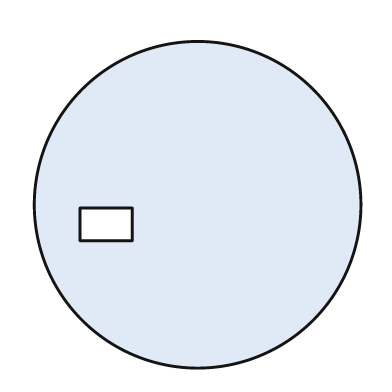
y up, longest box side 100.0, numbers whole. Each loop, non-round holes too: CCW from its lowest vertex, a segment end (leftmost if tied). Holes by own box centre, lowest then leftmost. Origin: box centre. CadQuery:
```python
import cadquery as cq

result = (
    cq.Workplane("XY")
    .moveTo(0.0, 0.0)
    .circle(50.0)
    .moveTo(-36.0, -11.0)
    .lineTo(-20.0, -11.0)
    .lineTo(-20.0, -1.0)
    .lineTo(-36.0, -1.0)
    .close()
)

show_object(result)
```